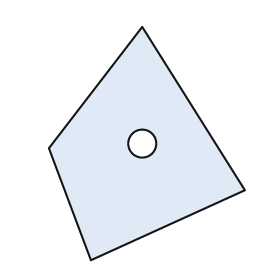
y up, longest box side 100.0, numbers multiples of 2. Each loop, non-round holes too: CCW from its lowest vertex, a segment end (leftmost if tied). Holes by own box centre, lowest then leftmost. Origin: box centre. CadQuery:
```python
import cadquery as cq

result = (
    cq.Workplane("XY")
    .moveTo(-24.0, -50.0)
    .lineTo(42.0, -20.0)
    .lineTo(-2.0, 50.0)
    .lineTo(-42.0, -2.0)
    .close()
    .moveTo(-2.0, 0.0)
    .circle(6.0)
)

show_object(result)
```